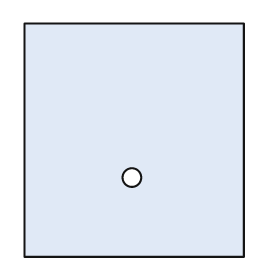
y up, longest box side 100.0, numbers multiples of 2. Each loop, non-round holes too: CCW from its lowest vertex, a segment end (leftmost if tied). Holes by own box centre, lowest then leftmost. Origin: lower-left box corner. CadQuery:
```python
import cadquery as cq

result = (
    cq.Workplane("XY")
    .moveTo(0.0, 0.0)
    .lineTo(94.0, 0.0)
    .lineTo(94.0, 100.0)
    .lineTo(0.0, 100.0)
    .close()
    .moveTo(46.0, 34.0)
    .circle(4.0)
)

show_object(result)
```